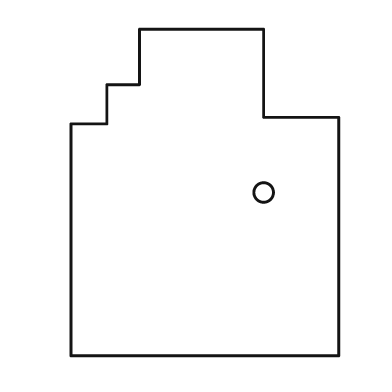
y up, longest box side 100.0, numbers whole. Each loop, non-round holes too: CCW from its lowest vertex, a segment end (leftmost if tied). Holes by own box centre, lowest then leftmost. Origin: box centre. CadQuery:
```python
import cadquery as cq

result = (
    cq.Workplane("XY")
    .moveTo(-41.0, -50.0)
    .lineTo(41.0, -50.0)
    .lineTo(41.0, 23.0)
    .lineTo(18.0, 23.0)
    .lineTo(18.0, 50.0)
    .lineTo(-20.0, 50.0)
    .lineTo(-20.0, 33.0)
    .lineTo(-30.0, 33.0)
    .lineTo(-30.0, 21.0)
    .lineTo(-41.0, 21.0)
    .close()
    .moveTo(18.0, 0.0)
    .circle(3.0)
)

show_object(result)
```